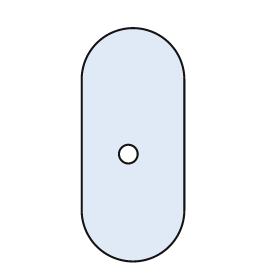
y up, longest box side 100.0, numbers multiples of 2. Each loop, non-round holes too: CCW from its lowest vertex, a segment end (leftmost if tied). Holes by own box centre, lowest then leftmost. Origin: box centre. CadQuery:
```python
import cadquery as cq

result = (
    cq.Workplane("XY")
    .moveTo(-22.0, -28.0)
    .threePointArc((0.0, -50.0), (22.0, -28.0))
    .lineTo(22.0, 28.0)
    .threePointArc((0.0, 50.0), (-22.0, 28.0))
    .close()
    .moveTo(-2.0, -4.0)
    .circle(4.0)
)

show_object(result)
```